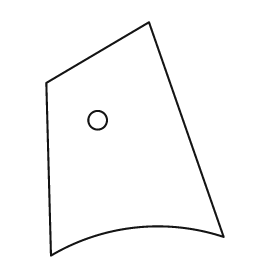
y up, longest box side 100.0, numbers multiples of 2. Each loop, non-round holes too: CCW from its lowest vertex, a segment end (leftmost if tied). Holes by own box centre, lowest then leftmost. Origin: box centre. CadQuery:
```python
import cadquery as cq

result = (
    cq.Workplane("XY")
    .moveTo(-36.0, -50.0)
    .threePointArc((0.0, -38.0), (38.0, -42.0))
    .lineTo(6.0, 50.0)
    .lineTo(-38.0, 24.0)
    .close()
    .moveTo(-16.0, 8.0)
    .circle(4.0)
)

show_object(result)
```